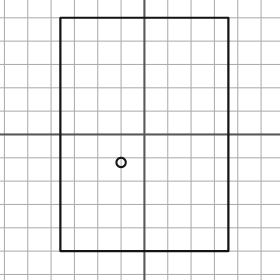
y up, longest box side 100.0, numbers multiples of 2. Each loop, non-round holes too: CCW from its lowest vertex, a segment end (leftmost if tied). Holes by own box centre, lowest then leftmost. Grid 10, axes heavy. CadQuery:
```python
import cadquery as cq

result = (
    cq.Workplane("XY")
    .moveTo(-36.0, -50.0)
    .lineTo(36.0, -50.0)
    .lineTo(36.0, 50.0)
    .lineTo(-36.0, 50.0)
    .close()
    .moveTo(-10.0, -12.0)
    .circle(2.0)
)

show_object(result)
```